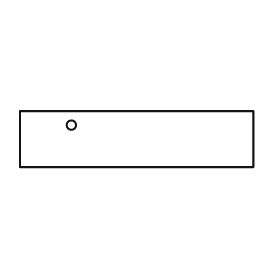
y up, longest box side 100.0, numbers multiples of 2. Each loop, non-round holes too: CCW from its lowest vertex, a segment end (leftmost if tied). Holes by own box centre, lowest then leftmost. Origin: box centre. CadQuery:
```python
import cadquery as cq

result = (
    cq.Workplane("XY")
    .moveTo(-50.0, -12.0)
    .lineTo(50.0, -12.0)
    .lineTo(50.0, 12.0)
    .lineTo(-50.0, 12.0)
    .close()
    .moveTo(-28.0, 6.0)
    .circle(2.0)
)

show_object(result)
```